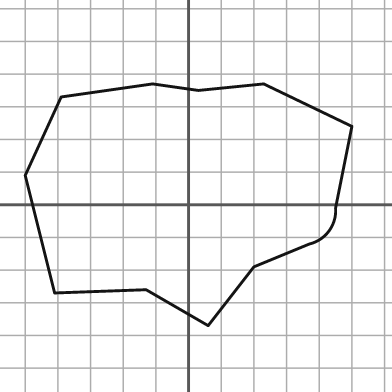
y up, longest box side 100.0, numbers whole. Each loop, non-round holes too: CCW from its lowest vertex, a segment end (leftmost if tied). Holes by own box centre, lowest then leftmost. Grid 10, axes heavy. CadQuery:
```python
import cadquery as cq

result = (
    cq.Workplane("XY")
    .moveTo(6.0, -37.0)
    .lineTo(20.0, -19.0)
    .lineTo(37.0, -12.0)
    .threePointArc((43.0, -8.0), (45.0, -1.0))
    .lineTo(50.0, 24.0)
    .lineTo(23.0, 37.0)
    .lineTo(3.0, 35.0)
    .lineTo(-11.0, 37.0)
    .lineTo(-39.0, 33.0)
    .lineTo(-50.0, 9.0)
    .lineTo(-41.0, -27.0)
    .lineTo(-13.0, -26.0)
    .close()
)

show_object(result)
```